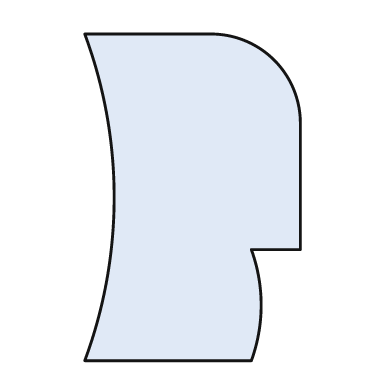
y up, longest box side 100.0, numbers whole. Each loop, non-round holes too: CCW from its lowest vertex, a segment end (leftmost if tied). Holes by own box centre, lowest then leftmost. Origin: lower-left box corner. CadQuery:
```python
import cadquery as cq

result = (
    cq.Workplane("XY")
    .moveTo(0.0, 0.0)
    .lineTo(51.0, 0.0)
    .threePointArc((54.0, 17.0), (51.0, 34.0))
    .lineTo(66.0, 34.0)
    .lineTo(66.0, 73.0)
    .threePointArc((58.0, 92.0), (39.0, 100.0))
    .lineTo(0.0, 100.0)
    .threePointArc((9.0, 50.0), (0.0, 0.0))
    .close()
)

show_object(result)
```